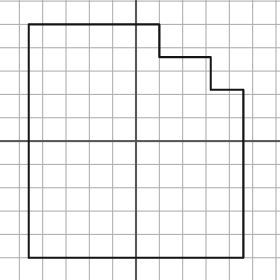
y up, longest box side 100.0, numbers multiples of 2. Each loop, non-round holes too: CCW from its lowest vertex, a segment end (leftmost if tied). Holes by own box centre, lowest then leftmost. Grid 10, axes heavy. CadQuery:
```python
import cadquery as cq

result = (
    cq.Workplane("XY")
    .moveTo(-46.0, -50.0)
    .lineTo(46.0, -50.0)
    .lineTo(46.0, 22.0)
    .lineTo(32.0, 22.0)
    .lineTo(32.0, 36.0)
    .lineTo(10.0, 36.0)
    .lineTo(10.0, 50.0)
    .lineTo(-46.0, 50.0)
    .close()
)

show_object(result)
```